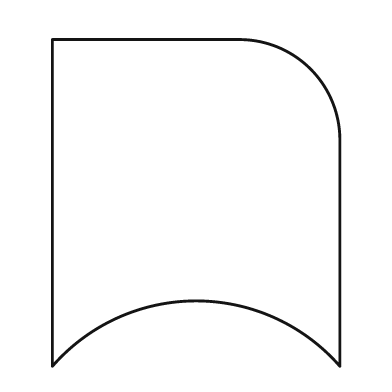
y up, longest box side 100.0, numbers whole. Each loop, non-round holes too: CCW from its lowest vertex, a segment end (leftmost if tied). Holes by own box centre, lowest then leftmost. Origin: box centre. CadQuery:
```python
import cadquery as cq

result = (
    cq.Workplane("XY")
    .moveTo(-44.0, -50.0)
    .threePointArc((0.0, -30.0), (44.0, -50.0))
    .lineTo(44.0, 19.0)
    .threePointArc((35.0, 41.0), (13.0, 50.0))
    .lineTo(-44.0, 50.0)
    .close()
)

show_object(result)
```